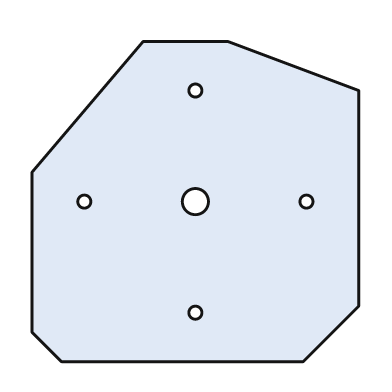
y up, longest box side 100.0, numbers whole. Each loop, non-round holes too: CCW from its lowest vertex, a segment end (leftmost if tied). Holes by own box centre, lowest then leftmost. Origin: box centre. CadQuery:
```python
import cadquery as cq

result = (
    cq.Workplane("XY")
    .moveTo(-41.0, -49.0)
    .lineTo(33.0, -49.0)
    .lineTo(50.0, -32.0)
    .lineTo(50.0, 34.0)
    .lineTo(10.0, 49.0)
    .lineTo(-16.0, 49.0)
    .lineTo(-50.0, 9.0)
    .lineTo(-50.0, -40.0)
    .close()
    .moveTo(0.0, -34.0)
    .circle(2.0)
    .moveTo(-34.0, 0.0)
    .circle(2.0)
    .moveTo(0.0, 0.0)
    .circle(4.0)
    .moveTo(34.0, 0.0)
    .circle(2.0)
    .moveTo(0.0, 34.0)
    .circle(2.0)
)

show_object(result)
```